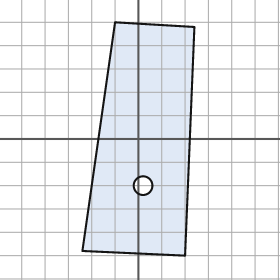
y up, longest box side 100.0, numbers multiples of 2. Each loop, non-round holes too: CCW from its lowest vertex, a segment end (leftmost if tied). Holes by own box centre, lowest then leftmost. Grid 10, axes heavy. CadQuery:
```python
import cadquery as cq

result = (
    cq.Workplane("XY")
    .moveTo(20.0, -50.0)
    .lineTo(24.0, 48.0)
    .lineTo(-10.0, 50.0)
    .lineTo(-24.0, -48.0)
    .close()
    .moveTo(2.0, -20.0)
    .circle(4.0)
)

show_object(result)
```